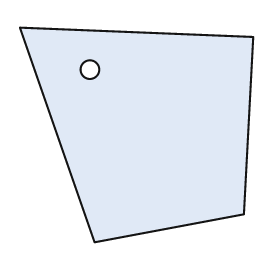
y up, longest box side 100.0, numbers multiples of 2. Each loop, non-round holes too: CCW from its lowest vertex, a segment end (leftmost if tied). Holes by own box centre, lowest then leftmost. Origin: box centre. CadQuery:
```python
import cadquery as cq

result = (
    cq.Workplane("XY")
    .moveTo(-18.0, -46.0)
    .lineTo(46.0, -34.0)
    .lineTo(50.0, 42.0)
    .lineTo(-50.0, 46.0)
    .close()
    .moveTo(-20.0, 28.0)
    .circle(4.0)
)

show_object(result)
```